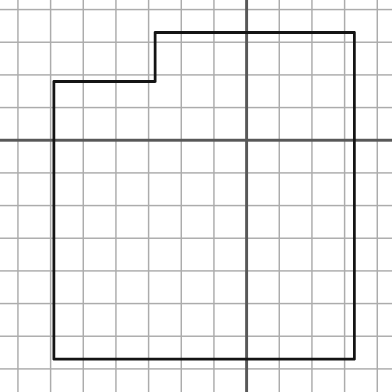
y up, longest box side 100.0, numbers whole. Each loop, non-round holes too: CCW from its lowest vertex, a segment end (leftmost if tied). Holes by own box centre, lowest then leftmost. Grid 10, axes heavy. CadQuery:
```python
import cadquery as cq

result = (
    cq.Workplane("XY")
    .moveTo(-59.0, -67.0)
    .lineTo(33.0, -67.0)
    .lineTo(33.0, 33.0)
    .lineTo(-28.0, 33.0)
    .lineTo(-28.0, 18.0)
    .lineTo(-59.0, 18.0)
    .close()
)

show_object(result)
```